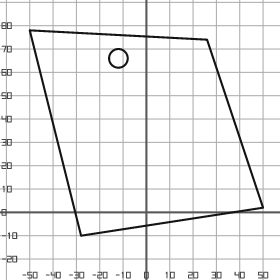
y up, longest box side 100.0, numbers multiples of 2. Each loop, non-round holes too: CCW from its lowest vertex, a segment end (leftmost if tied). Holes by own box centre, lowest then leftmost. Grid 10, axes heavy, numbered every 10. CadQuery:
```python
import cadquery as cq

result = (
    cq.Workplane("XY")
    .moveTo(-28.0, -10.0)
    .lineTo(50.0, 2.0)
    .lineTo(26.0, 74.0)
    .lineTo(-50.0, 78.0)
    .close()
    .moveTo(-12.0, 66.0)
    .circle(4.0)
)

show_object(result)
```